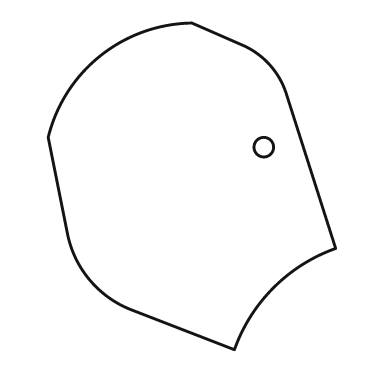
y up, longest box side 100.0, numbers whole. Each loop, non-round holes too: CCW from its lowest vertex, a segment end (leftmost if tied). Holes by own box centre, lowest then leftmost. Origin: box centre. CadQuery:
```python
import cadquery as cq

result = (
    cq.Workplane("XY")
    .moveTo(13.0, -50.0)
    .threePointArc((25.0, -31.0), (44.0, -19.0))
    .lineTo(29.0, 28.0)
    .threePointArc((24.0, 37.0), (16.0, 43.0))
    .lineTo(0.0, 50.0)
    .threePointArc((-28.0, 40.0), (-44.0, 15.0))
    .lineTo(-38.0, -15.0)
    .threePointArc((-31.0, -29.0), (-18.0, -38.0))
    .close()
    .moveTo(22.0, 12.0)
    .circle(3.0)
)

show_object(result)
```